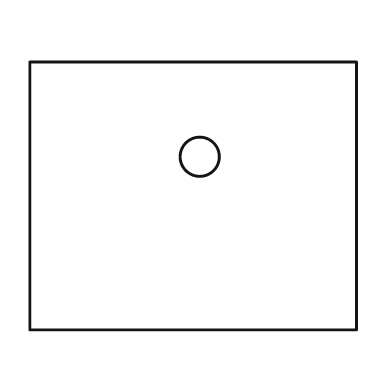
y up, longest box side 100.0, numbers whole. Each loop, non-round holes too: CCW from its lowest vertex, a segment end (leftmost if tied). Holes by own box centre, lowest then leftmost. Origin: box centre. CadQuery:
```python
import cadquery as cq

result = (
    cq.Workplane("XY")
    .moveTo(-50.0, -41.0)
    .lineTo(50.0, -41.0)
    .lineTo(50.0, 41.0)
    .lineTo(-50.0, 41.0)
    .close()
    .moveTo(2.0, 12.0)
    .circle(6.0)
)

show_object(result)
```